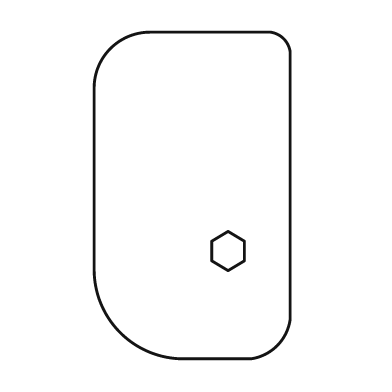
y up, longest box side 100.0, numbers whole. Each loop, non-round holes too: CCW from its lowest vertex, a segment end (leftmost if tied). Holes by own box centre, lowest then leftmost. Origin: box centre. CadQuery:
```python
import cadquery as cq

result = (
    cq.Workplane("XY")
    .moveTo(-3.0, -50.0)
    .lineTo(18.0, -50.0)
    .threePointArc((26.0, -46.0), (30.0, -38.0))
    .lineTo(30.0, 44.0)
    .threePointArc((28.0, 48.0), (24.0, 50.0))
    .lineTo(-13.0, 50.0)
    .threePointArc((-25.0, 45.0), (-30.0, 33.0))
    .lineTo(-30.0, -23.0)
    .threePointArc((-22.0, -42.0), (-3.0, -50.0))
    .close()
    .moveTo(11.0, -23.0)
    .lineTo(16.0, -20.0)
    .lineTo(16.0, -14.0)
    .lineTo(11.0, -11.0)
    .lineTo(6.0, -14.0)
    .lineTo(6.0, -20.0)
    .close()
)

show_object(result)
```